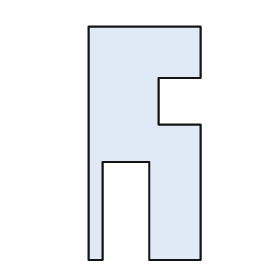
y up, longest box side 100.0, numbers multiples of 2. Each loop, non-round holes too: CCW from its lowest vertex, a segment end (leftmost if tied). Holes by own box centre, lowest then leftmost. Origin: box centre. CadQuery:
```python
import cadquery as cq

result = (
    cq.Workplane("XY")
    .moveTo(-24.0, -50.0)
    .lineTo(-18.0, -50.0)
    .lineTo(-18.0, -8.0)
    .lineTo(2.0, -8.0)
    .lineTo(2.0, -50.0)
    .lineTo(24.0, -50.0)
    .lineTo(24.0, 8.0)
    .lineTo(6.0, 8.0)
    .lineTo(6.0, 28.0)
    .lineTo(24.0, 28.0)
    .lineTo(24.0, 50.0)
    .lineTo(-24.0, 50.0)
    .close()
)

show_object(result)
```